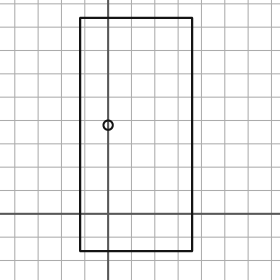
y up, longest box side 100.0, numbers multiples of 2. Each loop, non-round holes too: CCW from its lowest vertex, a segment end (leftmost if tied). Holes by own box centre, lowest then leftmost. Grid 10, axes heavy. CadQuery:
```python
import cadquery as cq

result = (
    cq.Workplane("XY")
    .moveTo(-12.0, -16.0)
    .lineTo(36.0, -16.0)
    .lineTo(36.0, 84.0)
    .lineTo(-12.0, 84.0)
    .close()
    .moveTo(0.0, 38.0)
    .circle(2.0)
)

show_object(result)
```